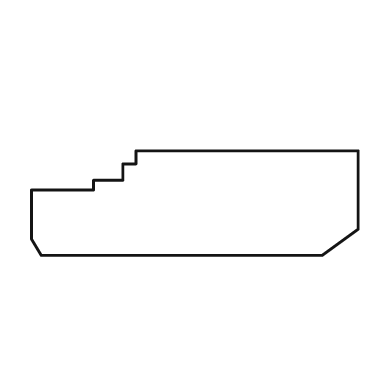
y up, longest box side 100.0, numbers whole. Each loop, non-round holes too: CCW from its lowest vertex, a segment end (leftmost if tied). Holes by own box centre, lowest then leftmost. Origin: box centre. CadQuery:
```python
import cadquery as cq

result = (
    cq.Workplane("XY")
    .moveTo(-47.0, -16.0)
    .lineTo(39.0, -16.0)
    .lineTo(50.0, -8.0)
    .lineTo(50.0, 16.0)
    .lineTo(-18.0, 16.0)
    .lineTo(-18.0, 12.0)
    .lineTo(-22.0, 12.0)
    .lineTo(-22.0, 7.0)
    .lineTo(-31.0, 7.0)
    .lineTo(-31.0, 4.0)
    .lineTo(-50.0, 4.0)
    .lineTo(-50.0, -11.0)
    .close()
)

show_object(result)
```